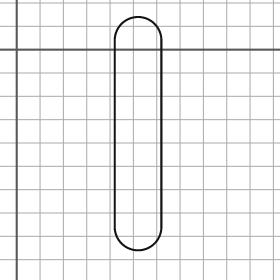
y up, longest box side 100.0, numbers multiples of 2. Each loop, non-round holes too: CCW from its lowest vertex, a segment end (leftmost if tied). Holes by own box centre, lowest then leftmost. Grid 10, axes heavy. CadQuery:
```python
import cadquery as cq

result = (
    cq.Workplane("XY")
    .moveTo(42.0, -76.0)
    .threePointArc((52.0, -86.0), (62.0, -76.0))
    .lineTo(62.0, 4.0)
    .threePointArc((52.0, 14.0), (42.0, 4.0))
    .close()
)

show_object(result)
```